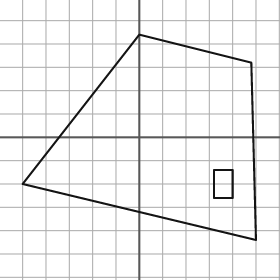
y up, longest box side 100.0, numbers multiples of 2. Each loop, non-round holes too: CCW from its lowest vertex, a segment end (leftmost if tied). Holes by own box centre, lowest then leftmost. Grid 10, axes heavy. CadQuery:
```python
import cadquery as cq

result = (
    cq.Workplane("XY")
    .moveTo(50.0, -44.0)
    .lineTo(48.0, 32.0)
    .lineTo(0.0, 44.0)
    .lineTo(-50.0, -20.0)
    .close()
    .moveTo(32.0, -26.0)
    .lineTo(40.0, -26.0)
    .lineTo(40.0, -14.0)
    .lineTo(32.0, -14.0)
    .close()
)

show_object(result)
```